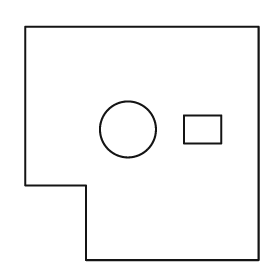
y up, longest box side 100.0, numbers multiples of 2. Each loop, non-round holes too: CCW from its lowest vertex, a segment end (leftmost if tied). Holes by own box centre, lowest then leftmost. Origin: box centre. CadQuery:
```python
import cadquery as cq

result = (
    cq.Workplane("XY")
    .moveTo(-24.0, -50.0)
    .lineTo(50.0, -50.0)
    .lineTo(50.0, 50.0)
    .lineTo(-50.0, 50.0)
    .lineTo(-50.0, -18.0)
    .lineTo(-24.0, -18.0)
    .close()
    .moveTo(-6.0, 6.0)
    .circle(12.0)
    .moveTo(18.0, 0.0)
    .lineTo(34.0, 0.0)
    .lineTo(34.0, 12.0)
    .lineTo(18.0, 12.0)
    .close()
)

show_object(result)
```